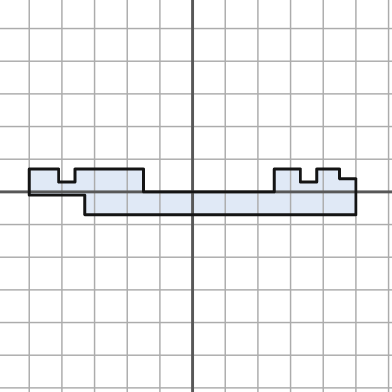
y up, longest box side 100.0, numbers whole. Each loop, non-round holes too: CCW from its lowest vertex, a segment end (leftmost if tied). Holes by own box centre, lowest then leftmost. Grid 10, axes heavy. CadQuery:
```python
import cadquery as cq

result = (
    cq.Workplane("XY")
    .moveTo(-33.0, -7.0)
    .lineTo(50.0, -7.0)
    .lineTo(50.0, 4.0)
    .lineTo(45.0, 4.0)
    .lineTo(45.0, 7.0)
    .lineTo(38.0, 7.0)
    .lineTo(38.0, 3.0)
    .lineTo(33.0, 3.0)
    .lineTo(33.0, 7.0)
    .lineTo(25.0, 7.0)
    .lineTo(25.0, 0.0)
    .lineTo(-15.0, 0.0)
    .lineTo(-15.0, 7.0)
    .lineTo(-36.0, 7.0)
    .lineTo(-36.0, 3.0)
    .lineTo(-41.0, 3.0)
    .lineTo(-41.0, 7.0)
    .lineTo(-50.0, 7.0)
    .lineTo(-50.0, -1.0)
    .lineTo(-33.0, -1.0)
    .close()
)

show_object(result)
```